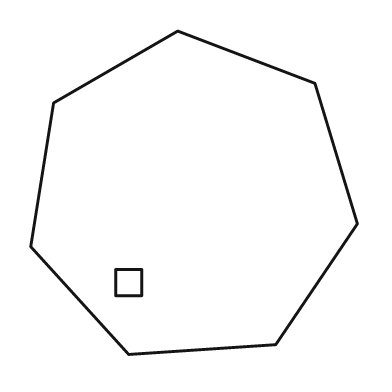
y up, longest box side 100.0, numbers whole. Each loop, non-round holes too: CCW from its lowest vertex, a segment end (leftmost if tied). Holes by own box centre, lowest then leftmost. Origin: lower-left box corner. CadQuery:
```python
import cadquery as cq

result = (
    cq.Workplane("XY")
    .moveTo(30.0, 0.0)
    .lineTo(75.0, 3.0)
    .lineTo(100.0, 40.0)
    .lineTo(87.0, 83.0)
    .lineTo(45.0, 99.0)
    .lineTo(7.0, 77.0)
    .lineTo(0.0, 33.0)
    .close()
    .moveTo(26.0, 18.0)
    .lineTo(34.0, 18.0)
    .lineTo(34.0, 26.0)
    .lineTo(26.0, 26.0)
    .close()
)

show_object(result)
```